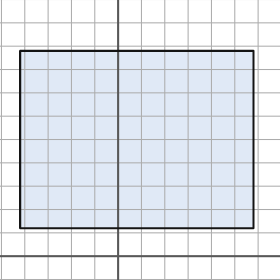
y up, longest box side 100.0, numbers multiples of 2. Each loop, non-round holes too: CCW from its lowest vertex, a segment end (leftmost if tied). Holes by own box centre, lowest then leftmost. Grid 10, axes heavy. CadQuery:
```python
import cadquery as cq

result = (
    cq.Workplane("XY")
    .moveTo(-42.0, 12.0)
    .lineTo(58.0, 12.0)
    .lineTo(58.0, 88.0)
    .lineTo(-42.0, 88.0)
    .close()
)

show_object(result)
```